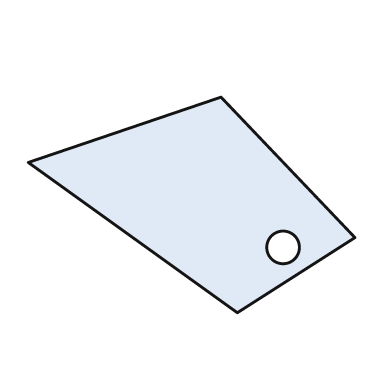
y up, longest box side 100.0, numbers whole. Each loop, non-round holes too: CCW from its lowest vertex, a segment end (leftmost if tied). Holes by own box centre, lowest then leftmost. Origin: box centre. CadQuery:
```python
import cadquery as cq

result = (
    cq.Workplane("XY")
    .moveTo(14.0, -33.0)
    .lineTo(50.0, -10.0)
    .lineTo(9.0, 33.0)
    .lineTo(-50.0, 13.0)
    .close()
    .moveTo(28.0, -13.0)
    .circle(5.0)
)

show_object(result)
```